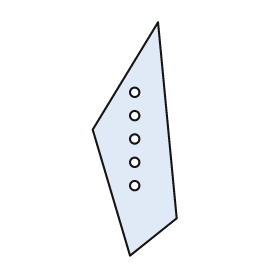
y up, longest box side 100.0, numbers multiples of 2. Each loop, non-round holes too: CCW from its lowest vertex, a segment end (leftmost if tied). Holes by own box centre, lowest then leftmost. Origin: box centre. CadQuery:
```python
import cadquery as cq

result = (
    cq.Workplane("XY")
    .moveTo(-2.0, -50.0)
    .lineTo(18.0, -34.0)
    .lineTo(10.0, 50.0)
    .lineTo(-18.0, 4.0)
    .close()
    .moveTo(0.0, -20.0)
    .circle(2.0)
    .moveTo(0.0, -10.0)
    .circle(2.0)
    .moveTo(0.0, 0.0)
    .circle(2.0)
    .moveTo(0.0, 10.0)
    .circle(2.0)
    .moveTo(0.0, 20.0)
    .circle(2.0)
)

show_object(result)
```